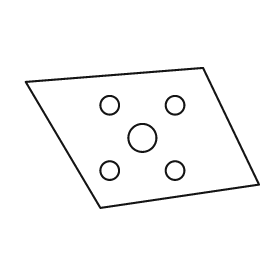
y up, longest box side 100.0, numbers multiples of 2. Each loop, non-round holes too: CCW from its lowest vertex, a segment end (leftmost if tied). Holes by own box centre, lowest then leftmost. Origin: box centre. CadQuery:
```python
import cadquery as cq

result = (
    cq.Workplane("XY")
    .moveTo(-18.0, -30.0)
    .lineTo(50.0, -20.0)
    .lineTo(26.0, 30.0)
    .lineTo(-50.0, 24.0)
    .close()
    .moveTo(-14.0, -14.0)
    .circle(4.0)
    .moveTo(14.0, -14.0)
    .circle(4.0)
    .moveTo(0.0, 0.0)
    .circle(6.0)
    .moveTo(-14.0, 14.0)
    .circle(4.0)
    .moveTo(14.0, 14.0)
    .circle(4.0)
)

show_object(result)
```